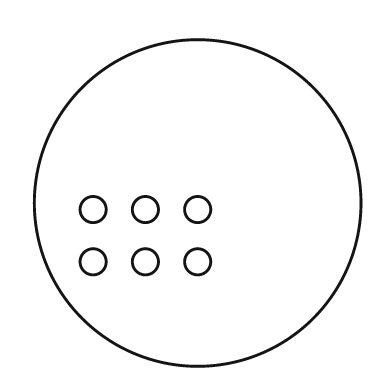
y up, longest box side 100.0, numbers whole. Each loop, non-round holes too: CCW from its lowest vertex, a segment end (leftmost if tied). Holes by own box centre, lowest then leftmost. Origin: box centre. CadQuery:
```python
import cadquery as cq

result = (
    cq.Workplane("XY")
    .moveTo(0.0, 0.0)
    .circle(50.0)
    .moveTo(-32.0, -18.0)
    .circle(4.0)
    .moveTo(-16.0, -18.0)
    .circle(4.0)
    .moveTo(0.0, -18.0)
    .circle(4.0)
    .moveTo(-32.0, -2.0)
    .circle(4.0)
    .moveTo(-16.0, -2.0)
    .circle(4.0)
    .moveTo(0.0, -2.0)
    .circle(4.0)
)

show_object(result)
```